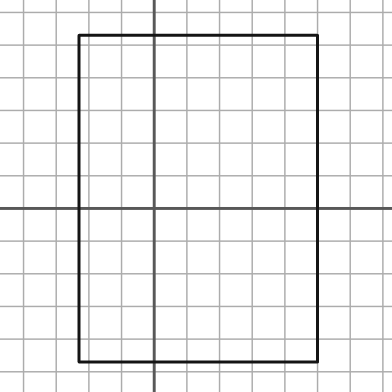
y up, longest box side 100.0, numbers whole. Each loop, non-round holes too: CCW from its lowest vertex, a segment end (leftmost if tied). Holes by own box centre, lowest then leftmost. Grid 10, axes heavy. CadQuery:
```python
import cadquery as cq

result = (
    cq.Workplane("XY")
    .moveTo(-23.0, -47.0)
    .lineTo(50.0, -47.0)
    .lineTo(50.0, 53.0)
    .lineTo(-23.0, 53.0)
    .close()
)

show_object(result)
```